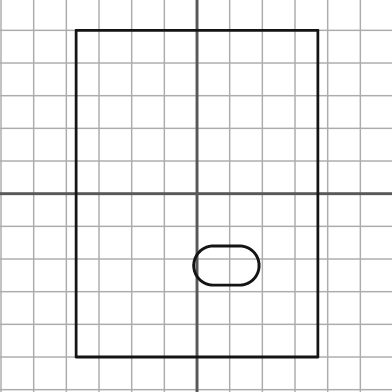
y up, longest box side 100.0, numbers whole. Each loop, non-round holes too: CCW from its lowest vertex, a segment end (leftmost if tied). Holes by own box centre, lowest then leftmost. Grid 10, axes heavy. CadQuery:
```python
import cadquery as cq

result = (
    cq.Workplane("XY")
    .moveTo(-37.0, -50.0)
    .lineTo(37.0, -50.0)
    .lineTo(37.0, 50.0)
    .lineTo(-37.0, 50.0)
    .close()
    .moveTo(5.0, -28.0)
    .lineTo(13.0, -28.0)
    .threePointArc((19.0, -22.0), (13.0, -16.0))
    .lineTo(5.0, -16.0)
    .threePointArc((-1.0, -22.0), (5.0, -28.0))
    .close()
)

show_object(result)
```